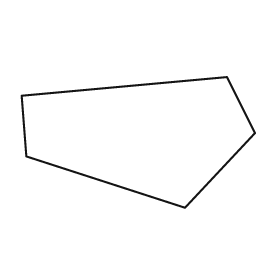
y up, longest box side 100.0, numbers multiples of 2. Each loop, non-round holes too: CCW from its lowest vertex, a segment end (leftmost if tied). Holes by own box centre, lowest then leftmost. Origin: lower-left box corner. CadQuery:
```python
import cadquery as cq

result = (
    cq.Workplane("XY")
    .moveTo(70.0, 0.0)
    .lineTo(100.0, 32.0)
    .lineTo(88.0, 56.0)
    .lineTo(0.0, 48.0)
    .lineTo(2.0, 22.0)
    .close()
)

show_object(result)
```